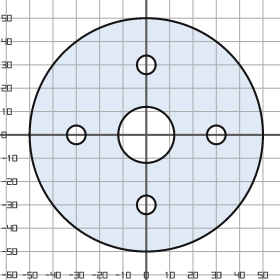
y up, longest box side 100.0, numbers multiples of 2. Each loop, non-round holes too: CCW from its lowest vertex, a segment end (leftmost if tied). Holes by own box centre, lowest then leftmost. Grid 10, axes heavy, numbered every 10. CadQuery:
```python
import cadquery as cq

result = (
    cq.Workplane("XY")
    .moveTo(0.0, 0.0)
    .circle(50.0)
    .moveTo(0.0, -30.0)
    .circle(4.0)
    .moveTo(-30.0, 0.0)
    .circle(4.0)
    .moveTo(0.0, 0.0)
    .circle(12.0)
    .moveTo(30.0, 0.0)
    .circle(4.0)
    .moveTo(0.0, 30.0)
    .circle(4.0)
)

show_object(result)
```